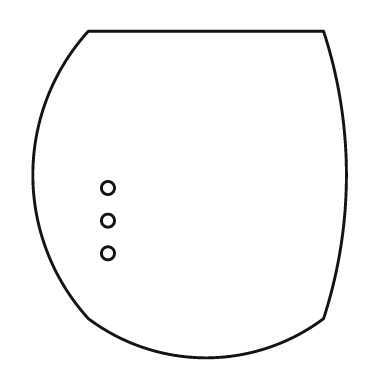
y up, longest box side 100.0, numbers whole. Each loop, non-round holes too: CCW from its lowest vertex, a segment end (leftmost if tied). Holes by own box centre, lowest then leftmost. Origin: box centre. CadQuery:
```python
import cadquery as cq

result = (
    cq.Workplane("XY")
    .moveTo(-31.0, -38.0)
    .threePointArc((5.0, -50.0), (41.0, -38.0))
    .threePointArc((48.0, 6.0), (41.0, 50.0))
    .lineTo(-31.0, 50.0)
    .threePointArc((-48.0, 6.0), (-31.0, -38.0))
    .close()
    .moveTo(-25.0, -18.0)
    .circle(2.0)
    .moveTo(-25.0, -8.0)
    .circle(2.0)
    .moveTo(-25.0, 2.0)
    .circle(2.0)
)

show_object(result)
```